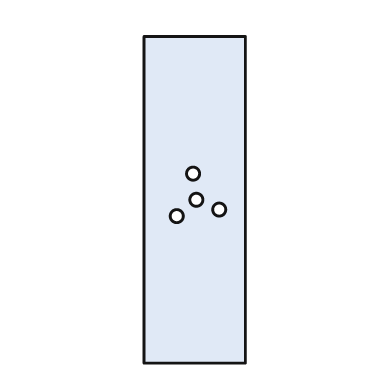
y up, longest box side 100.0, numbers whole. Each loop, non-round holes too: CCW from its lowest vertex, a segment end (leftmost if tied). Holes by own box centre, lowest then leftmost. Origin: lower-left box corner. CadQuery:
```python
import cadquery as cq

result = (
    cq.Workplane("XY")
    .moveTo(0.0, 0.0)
    .lineTo(31.0, 0.0)
    .lineTo(31.0, 100.0)
    .lineTo(0.0, 100.0)
    .close()
    .moveTo(10.0, 45.0)
    .circle(2.0)
    .moveTo(23.0, 47.0)
    .circle(2.0)
    .moveTo(16.0, 50.0)
    .circle(2.0)
    .moveTo(15.0, 58.0)
    .circle(2.0)
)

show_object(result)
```